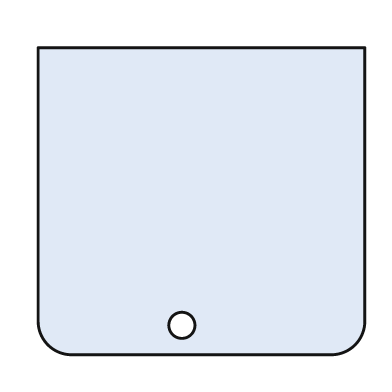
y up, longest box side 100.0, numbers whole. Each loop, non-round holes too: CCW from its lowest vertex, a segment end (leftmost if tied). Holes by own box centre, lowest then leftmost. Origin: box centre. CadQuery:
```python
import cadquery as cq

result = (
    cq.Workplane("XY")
    .moveTo(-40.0, -47.0)
    .lineTo(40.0, -47.0)
    .threePointArc((47.0, -44.0), (50.0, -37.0))
    .lineTo(50.0, 47.0)
    .lineTo(-50.0, 47.0)
    .lineTo(-50.0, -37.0)
    .threePointArc((-47.0, -44.0), (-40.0, -47.0))
    .close()
    .moveTo(-6.0, -38.0)
    .circle(4.0)
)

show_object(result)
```